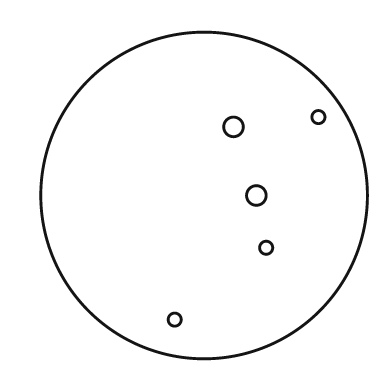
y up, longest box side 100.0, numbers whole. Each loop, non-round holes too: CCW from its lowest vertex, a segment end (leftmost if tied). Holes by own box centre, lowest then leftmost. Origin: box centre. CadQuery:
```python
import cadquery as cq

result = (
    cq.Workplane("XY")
    .moveTo(0.0, 0.0)
    .circle(50.0)
    .moveTo(-9.0, -38.0)
    .circle(2.0)
    .moveTo(19.0, -16.0)
    .circle(2.0)
    .moveTo(16.0, 0.0)
    .circle(3.0)
    .moveTo(9.0, 21.0)
    .circle(3.0)
    .moveTo(35.0, 24.0)
    .circle(2.0)
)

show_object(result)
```